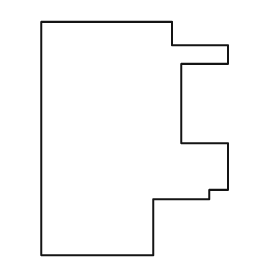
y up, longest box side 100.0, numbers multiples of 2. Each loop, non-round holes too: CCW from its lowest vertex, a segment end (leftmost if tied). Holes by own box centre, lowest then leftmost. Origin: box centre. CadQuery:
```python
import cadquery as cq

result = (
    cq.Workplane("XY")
    .moveTo(-40.0, -50.0)
    .lineTo(8.0, -50.0)
    .lineTo(8.0, -26.0)
    .lineTo(32.0, -26.0)
    .lineTo(32.0, -22.0)
    .lineTo(40.0, -22.0)
    .lineTo(40.0, -2.0)
    .lineTo(20.0, -2.0)
    .lineTo(20.0, 32.0)
    .lineTo(40.0, 32.0)
    .lineTo(40.0, 40.0)
    .lineTo(16.0, 40.0)
    .lineTo(16.0, 50.0)
    .lineTo(-40.0, 50.0)
    .close()
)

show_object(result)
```